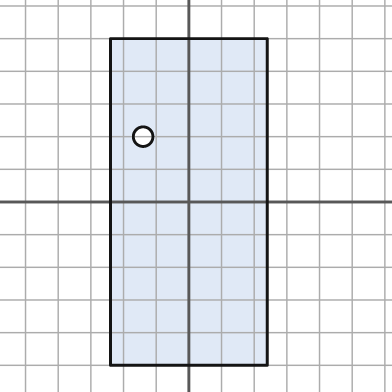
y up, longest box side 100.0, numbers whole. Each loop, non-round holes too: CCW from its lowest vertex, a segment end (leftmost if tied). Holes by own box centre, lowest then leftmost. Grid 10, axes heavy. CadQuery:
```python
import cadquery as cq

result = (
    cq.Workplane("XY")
    .moveTo(-24.0, -50.0)
    .lineTo(24.0, -50.0)
    .lineTo(24.0, 50.0)
    .lineTo(-24.0, 50.0)
    .close()
    .moveTo(-14.0, 20.0)
    .circle(3.0)
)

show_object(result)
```